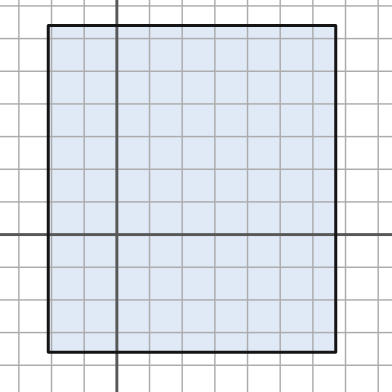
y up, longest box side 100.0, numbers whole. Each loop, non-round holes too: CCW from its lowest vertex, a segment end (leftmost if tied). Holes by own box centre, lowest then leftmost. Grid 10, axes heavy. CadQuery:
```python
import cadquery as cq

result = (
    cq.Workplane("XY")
    .moveTo(-21.0, -36.0)
    .lineTo(67.0, -36.0)
    .lineTo(67.0, 64.0)
    .lineTo(-21.0, 64.0)
    .close()
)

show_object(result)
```